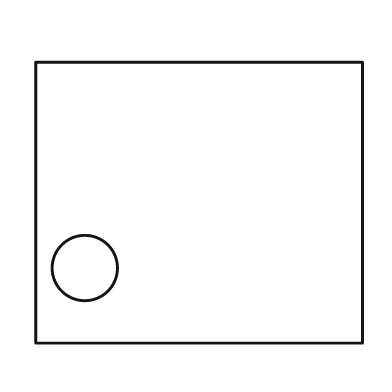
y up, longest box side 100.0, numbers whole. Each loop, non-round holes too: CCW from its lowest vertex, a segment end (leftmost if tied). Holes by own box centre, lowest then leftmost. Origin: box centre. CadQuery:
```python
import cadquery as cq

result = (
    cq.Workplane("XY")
    .moveTo(-50.0, -43.0)
    .lineTo(50.0, -43.0)
    .lineTo(50.0, 43.0)
    .lineTo(-50.0, 43.0)
    .close()
    .moveTo(-35.0, -20.0)
    .circle(10.0)
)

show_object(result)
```